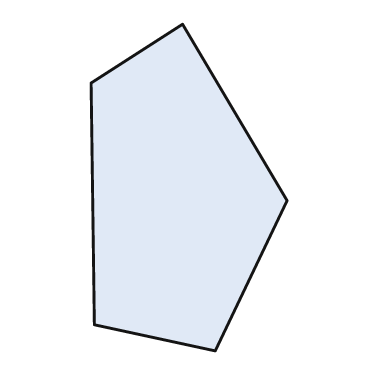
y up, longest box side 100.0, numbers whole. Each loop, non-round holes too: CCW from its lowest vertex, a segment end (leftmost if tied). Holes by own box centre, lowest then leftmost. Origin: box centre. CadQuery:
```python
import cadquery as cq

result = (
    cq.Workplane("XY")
    .moveTo(8.0, -50.0)
    .lineTo(30.0, -4.0)
    .lineTo(-2.0, 50.0)
    .lineTo(-30.0, 32.0)
    .lineTo(-29.0, -42.0)
    .close()
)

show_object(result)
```